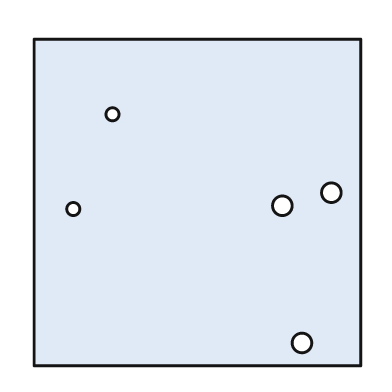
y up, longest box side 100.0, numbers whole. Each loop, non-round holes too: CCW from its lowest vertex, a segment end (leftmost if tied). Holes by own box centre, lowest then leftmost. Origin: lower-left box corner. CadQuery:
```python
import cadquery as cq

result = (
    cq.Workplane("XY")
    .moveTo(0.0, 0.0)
    .lineTo(100.0, 0.0)
    .lineTo(100.0, 100.0)
    .lineTo(0.0, 100.0)
    .close()
    .moveTo(82.0, 7.0)
    .circle(3.0)
    .moveTo(12.0, 48.0)
    .circle(2.0)
    .moveTo(76.0, 49.0)
    .circle(3.0)
    .moveTo(91.0, 53.0)
    .circle(3.0)
    .moveTo(24.0, 77.0)
    .circle(2.0)
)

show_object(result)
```